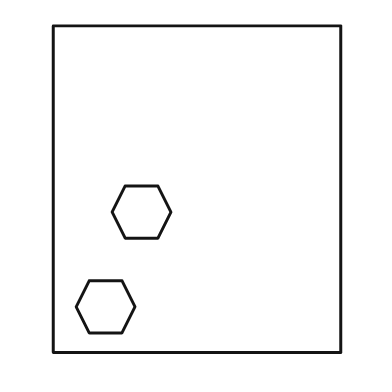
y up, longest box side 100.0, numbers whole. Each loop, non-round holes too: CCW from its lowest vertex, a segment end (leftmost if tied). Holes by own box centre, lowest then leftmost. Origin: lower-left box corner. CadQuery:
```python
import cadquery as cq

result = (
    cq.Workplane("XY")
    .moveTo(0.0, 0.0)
    .lineTo(88.0, 0.0)
    .lineTo(88.0, 100.0)
    .lineTo(0.0, 100.0)
    .close()
    .moveTo(11.0, 6.0)
    .lineTo(21.0, 6.0)
    .lineTo(25.0, 14.0)
    .lineTo(21.0, 22.0)
    .lineTo(11.0, 22.0)
    .lineTo(7.0, 14.0)
    .close()
    .moveTo(22.0, 35.0)
    .lineTo(32.0, 35.0)
    .lineTo(36.0, 43.0)
    .lineTo(32.0, 51.0)
    .lineTo(22.0, 51.0)
    .lineTo(18.0, 43.0)
    .close()
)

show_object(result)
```